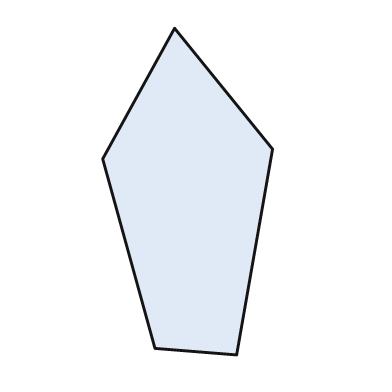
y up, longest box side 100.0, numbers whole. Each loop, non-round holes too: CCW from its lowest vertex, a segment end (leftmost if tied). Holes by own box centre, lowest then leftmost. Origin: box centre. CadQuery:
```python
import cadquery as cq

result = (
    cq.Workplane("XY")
    .moveTo(15.0, -50.0)
    .lineTo(26.0, 13.0)
    .lineTo(-4.0, 50.0)
    .lineTo(-26.0, 10.0)
    .lineTo(-10.0, -48.0)
    .close()
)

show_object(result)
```